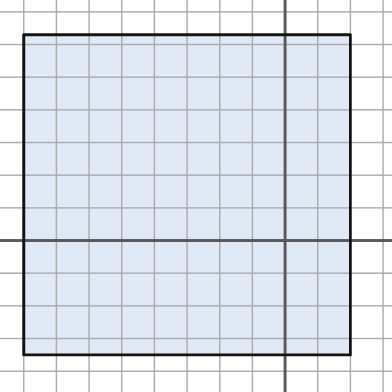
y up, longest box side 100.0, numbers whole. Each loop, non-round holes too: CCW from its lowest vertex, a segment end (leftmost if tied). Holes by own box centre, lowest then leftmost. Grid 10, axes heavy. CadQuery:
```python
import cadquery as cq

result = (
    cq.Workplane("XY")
    .moveTo(-80.0, -35.0)
    .lineTo(20.0, -35.0)
    .lineTo(20.0, 63.0)
    .lineTo(-80.0, 63.0)
    .close()
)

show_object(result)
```